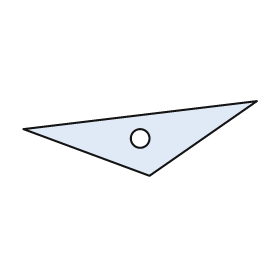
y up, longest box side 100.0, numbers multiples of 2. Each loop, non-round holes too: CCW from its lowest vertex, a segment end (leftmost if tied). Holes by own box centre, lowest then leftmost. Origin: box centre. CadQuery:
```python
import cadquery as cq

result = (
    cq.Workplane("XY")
    .moveTo(4.0, -16.0)
    .lineTo(50.0, 16.0)
    .lineTo(-50.0, 4.0)
    .close()
    .moveTo(0.0, 0.0)
    .circle(4.0)
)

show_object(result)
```